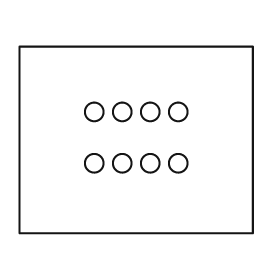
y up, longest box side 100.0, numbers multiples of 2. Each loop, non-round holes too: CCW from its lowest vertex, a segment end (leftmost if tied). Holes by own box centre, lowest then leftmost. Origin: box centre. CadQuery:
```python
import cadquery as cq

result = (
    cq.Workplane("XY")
    .moveTo(-50.0, -40.0)
    .lineTo(50.0, -40.0)
    .lineTo(50.0, 40.0)
    .lineTo(-50.0, 40.0)
    .close()
    .moveTo(-18.0, -10.0)
    .circle(4.0)
    .moveTo(-6.0, -10.0)
    .circle(4.0)
    .moveTo(6.0, -10.0)
    .circle(4.0)
    .moveTo(18.0, -10.0)
    .circle(4.0)
    .moveTo(-18.0, 12.0)
    .circle(4.0)
    .moveTo(-6.0, 12.0)
    .circle(4.0)
    .moveTo(6.0, 12.0)
    .circle(4.0)
    .moveTo(18.0, 12.0)
    .circle(4.0)
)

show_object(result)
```